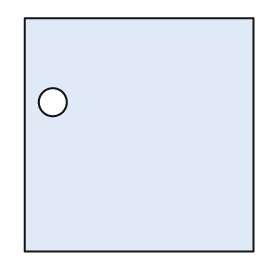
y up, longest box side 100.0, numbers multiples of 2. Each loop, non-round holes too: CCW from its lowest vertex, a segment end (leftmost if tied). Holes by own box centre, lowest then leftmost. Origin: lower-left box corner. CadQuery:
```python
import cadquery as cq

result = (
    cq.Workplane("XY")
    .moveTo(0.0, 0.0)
    .lineTo(98.0, 0.0)
    .lineTo(98.0, 100.0)
    .lineTo(0.0, 100.0)
    .close()
    .moveTo(12.0, 64.0)
    .circle(6.0)
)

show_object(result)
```